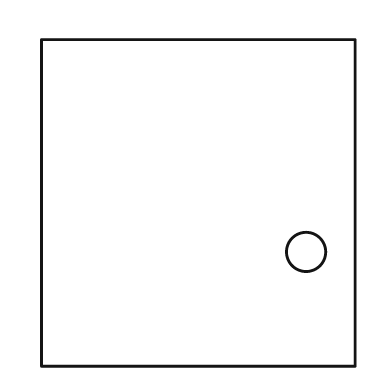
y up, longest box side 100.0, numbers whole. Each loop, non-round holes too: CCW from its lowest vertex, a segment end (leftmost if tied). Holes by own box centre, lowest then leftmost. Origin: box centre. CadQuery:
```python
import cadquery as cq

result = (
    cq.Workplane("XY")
    .moveTo(-48.0, -50.0)
    .lineTo(48.0, -50.0)
    .lineTo(48.0, 50.0)
    .lineTo(-48.0, 50.0)
    .close()
    .moveTo(33.0, -15.0)
    .circle(6.0)
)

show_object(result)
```